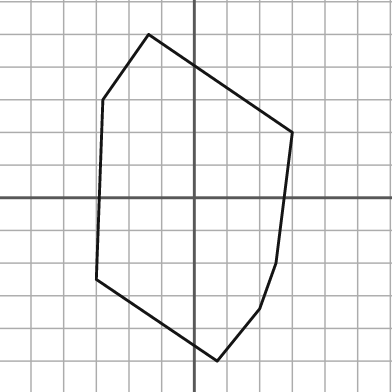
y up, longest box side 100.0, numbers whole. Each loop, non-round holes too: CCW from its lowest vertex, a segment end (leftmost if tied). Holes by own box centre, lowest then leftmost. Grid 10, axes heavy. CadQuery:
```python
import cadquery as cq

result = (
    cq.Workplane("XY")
    .moveTo(7.0, -50.0)
    .lineTo(20.0, -34.0)
    .lineTo(25.0, -20.0)
    .lineTo(30.0, 20.0)
    .lineTo(-14.0, 50.0)
    .lineTo(-28.0, 30.0)
    .lineTo(-30.0, -25.0)
    .close()
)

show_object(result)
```